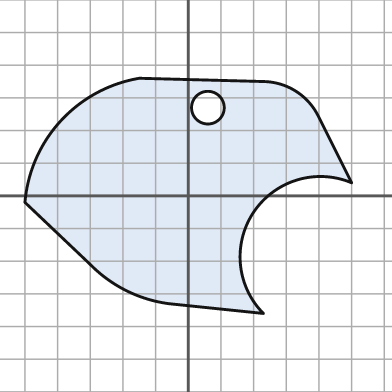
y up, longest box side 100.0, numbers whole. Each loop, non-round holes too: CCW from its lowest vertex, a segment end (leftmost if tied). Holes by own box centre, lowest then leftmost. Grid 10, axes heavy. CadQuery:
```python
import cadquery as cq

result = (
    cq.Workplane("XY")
    .moveTo(23.0, -36.0)
    .threePointArc((20.0, -5.0), (50.0, 4.0))
    .lineTo(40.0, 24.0)
    .threePointArc((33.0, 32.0), (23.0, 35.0))
    .lineTo(-15.0, 36.0)
    .threePointArc((-39.0, 23.0), (-50.0, -2.0))
    .lineTo(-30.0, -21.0)
    .threePointArc((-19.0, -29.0), (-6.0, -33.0))
    .close()
    .moveTo(6.0, 27.0)
    .circle(5.0)
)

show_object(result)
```